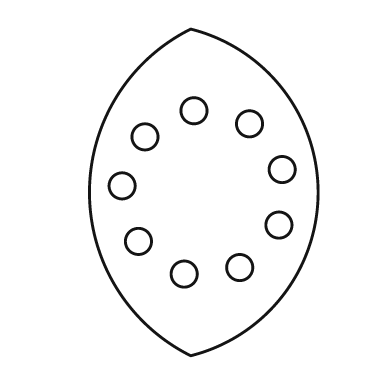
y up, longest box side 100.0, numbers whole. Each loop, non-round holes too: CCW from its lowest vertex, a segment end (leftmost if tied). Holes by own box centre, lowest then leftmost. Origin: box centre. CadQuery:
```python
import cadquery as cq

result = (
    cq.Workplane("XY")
    .moveTo(-4.0, -50.0)
    .threePointArc((35.0, 0.0), (-4.0, 50.0))
    .threePointArc((-35.0, 0.0), (-4.0, -50.0))
    .close()
    .moveTo(-6.0, -25.0)
    .circle(4.0)
    .moveTo(11.0, -23.0)
    .circle(4.0)
    .moveTo(-20.0, -15.0)
    .circle(4.0)
    .moveTo(23.0, -10.0)
    .circle(4.0)
    .moveTo(-25.0, 2.0)
    .circle(4.0)
    .moveTo(24.0, 7.0)
    .circle(4.0)
    .moveTo(-18.0, 17.0)
    .circle(4.0)
    .moveTo(14.0, 21.0)
    .circle(4.0)
    .moveTo(-3.0, 25.0)
    .circle(4.0)
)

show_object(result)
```